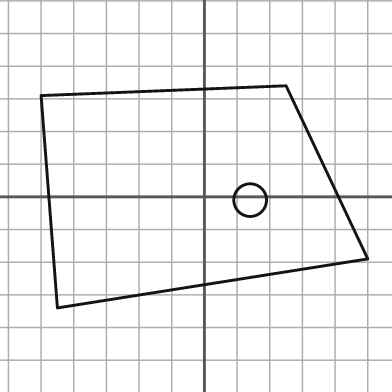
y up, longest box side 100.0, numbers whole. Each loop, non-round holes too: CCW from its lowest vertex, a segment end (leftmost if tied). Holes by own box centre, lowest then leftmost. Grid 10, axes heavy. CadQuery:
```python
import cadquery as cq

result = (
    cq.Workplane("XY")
    .moveTo(-45.0, -34.0)
    .lineTo(50.0, -19.0)
    .lineTo(25.0, 34.0)
    .lineTo(-50.0, 31.0)
    .close()
    .moveTo(14.0, -1.0)
    .circle(5.0)
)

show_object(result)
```